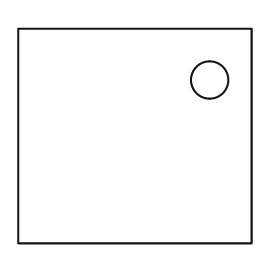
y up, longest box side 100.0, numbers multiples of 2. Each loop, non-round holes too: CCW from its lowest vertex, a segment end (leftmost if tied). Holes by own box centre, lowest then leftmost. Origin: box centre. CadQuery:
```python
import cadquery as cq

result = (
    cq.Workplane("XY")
    .moveTo(-50.0, -46.0)
    .lineTo(50.0, -46.0)
    .lineTo(50.0, 46.0)
    .lineTo(-50.0, 46.0)
    .close()
    .moveTo(32.0, 24.0)
    .circle(8.0)
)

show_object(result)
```